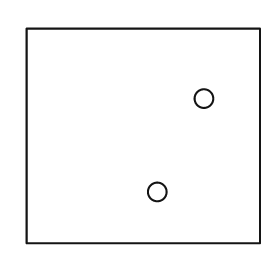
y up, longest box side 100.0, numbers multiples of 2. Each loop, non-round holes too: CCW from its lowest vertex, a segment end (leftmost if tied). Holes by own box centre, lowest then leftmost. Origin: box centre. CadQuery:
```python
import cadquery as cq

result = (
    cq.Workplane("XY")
    .moveTo(-50.0, -46.0)
    .lineTo(50.0, -46.0)
    .lineTo(50.0, 46.0)
    .lineTo(-50.0, 46.0)
    .close()
    .moveTo(6.0, -24.0)
    .circle(4.0)
    .moveTo(26.0, 16.0)
    .circle(4.0)
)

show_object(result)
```